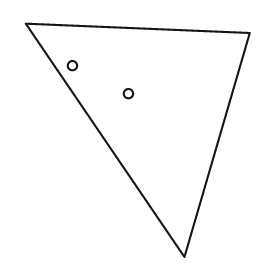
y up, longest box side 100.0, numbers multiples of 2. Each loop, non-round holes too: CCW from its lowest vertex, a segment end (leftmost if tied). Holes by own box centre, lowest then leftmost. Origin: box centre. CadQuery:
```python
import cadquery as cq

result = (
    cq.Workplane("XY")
    .moveTo(20.0, -50.0)
    .lineTo(48.0, 46.0)
    .lineTo(-48.0, 50.0)
    .close()
    .moveTo(-4.0, 20.0)
    .circle(2.0)
    .moveTo(-28.0, 32.0)
    .circle(2.0)
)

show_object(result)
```